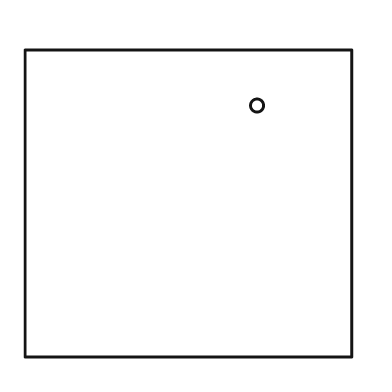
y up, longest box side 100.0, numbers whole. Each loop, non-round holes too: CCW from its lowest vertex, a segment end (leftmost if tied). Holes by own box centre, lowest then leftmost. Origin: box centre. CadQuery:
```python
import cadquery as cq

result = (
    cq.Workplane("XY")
    .moveTo(-50.0, -47.0)
    .lineTo(50.0, -47.0)
    .lineTo(50.0, 47.0)
    .lineTo(-50.0, 47.0)
    .close()
    .moveTo(21.0, 30.0)
    .circle(2.0)
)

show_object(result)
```